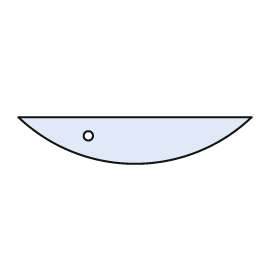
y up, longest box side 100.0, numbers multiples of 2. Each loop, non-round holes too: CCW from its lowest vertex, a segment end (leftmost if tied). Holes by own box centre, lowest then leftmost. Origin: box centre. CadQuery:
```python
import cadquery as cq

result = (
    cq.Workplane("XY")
    .moveTo(-50.0, 10.0)
    .threePointArc((0.0, -10.0), (50.0, 10.0))
    .close()
    .moveTo(-20.0, 2.0)
    .circle(2.0)
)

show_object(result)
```